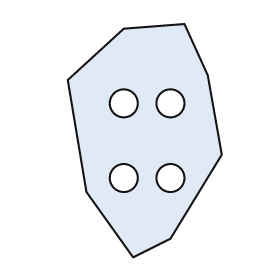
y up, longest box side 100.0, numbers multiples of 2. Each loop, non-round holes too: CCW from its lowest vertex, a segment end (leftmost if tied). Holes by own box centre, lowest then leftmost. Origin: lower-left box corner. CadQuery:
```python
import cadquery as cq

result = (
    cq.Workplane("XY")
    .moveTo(28.0, 0.0)
    .lineTo(44.0, 8.0)
    .lineTo(66.0, 44.0)
    .lineTo(60.0, 78.0)
    .lineTo(50.0, 100.0)
    .lineTo(24.0, 98.0)
    .lineTo(0.0, 76.0)
    .lineTo(8.0, 28.0)
    .close()
    .moveTo(24.0, 34.0)
    .circle(6.0)
    .moveTo(44.0, 34.0)
    .circle(6.0)
    .moveTo(24.0, 66.0)
    .circle(6.0)
    .moveTo(44.0, 66.0)
    .circle(6.0)
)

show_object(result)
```